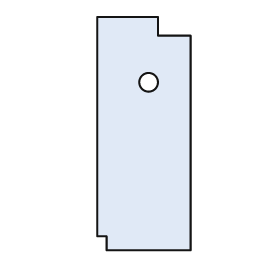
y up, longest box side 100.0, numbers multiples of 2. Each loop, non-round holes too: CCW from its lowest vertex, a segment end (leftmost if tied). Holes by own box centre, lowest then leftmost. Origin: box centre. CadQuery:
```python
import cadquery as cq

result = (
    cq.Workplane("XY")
    .moveTo(-16.0, -50.0)
    .lineTo(20.0, -50.0)
    .lineTo(20.0, 42.0)
    .lineTo(6.0, 42.0)
    .lineTo(6.0, 50.0)
    .lineTo(-20.0, 50.0)
    .lineTo(-20.0, -44.0)
    .lineTo(-16.0, -44.0)
    .close()
    .moveTo(2.0, 22.0)
    .circle(4.0)
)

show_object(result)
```